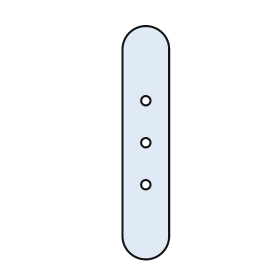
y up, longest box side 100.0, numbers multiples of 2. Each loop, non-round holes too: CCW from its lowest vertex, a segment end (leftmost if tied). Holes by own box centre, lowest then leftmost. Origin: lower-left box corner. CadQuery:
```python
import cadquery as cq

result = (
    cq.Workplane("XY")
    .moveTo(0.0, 10.0)
    .threePointArc((10.0, 0.0), (20.0, 10.0))
    .lineTo(20.0, 90.0)
    .threePointArc((10.0, 100.0), (0.0, 90.0))
    .close()
    .moveTo(10.0, 32.0)
    .circle(2.0)
    .moveTo(10.0, 50.0)
    .circle(2.0)
    .moveTo(10.0, 68.0)
    .circle(2.0)
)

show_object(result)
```